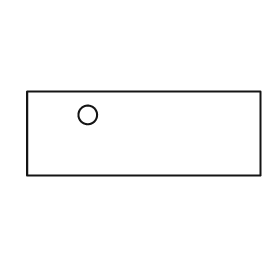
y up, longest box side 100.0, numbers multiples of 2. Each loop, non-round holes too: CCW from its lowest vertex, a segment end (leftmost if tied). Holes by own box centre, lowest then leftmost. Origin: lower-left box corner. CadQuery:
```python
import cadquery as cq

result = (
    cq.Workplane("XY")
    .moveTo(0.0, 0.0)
    .lineTo(100.0, 0.0)
    .lineTo(100.0, 36.0)
    .lineTo(0.0, 36.0)
    .close()
    .moveTo(26.0, 26.0)
    .circle(4.0)
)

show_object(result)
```